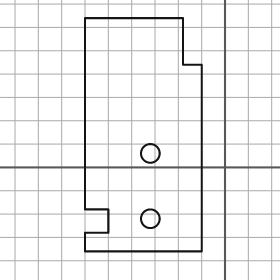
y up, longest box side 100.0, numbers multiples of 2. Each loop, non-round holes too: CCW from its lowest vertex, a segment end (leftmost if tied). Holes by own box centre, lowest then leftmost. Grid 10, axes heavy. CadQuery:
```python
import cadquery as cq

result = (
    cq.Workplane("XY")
    .moveTo(-60.0, -36.0)
    .lineTo(-10.0, -36.0)
    .lineTo(-10.0, 44.0)
    .lineTo(-18.0, 44.0)
    .lineTo(-18.0, 64.0)
    .lineTo(-60.0, 64.0)
    .lineTo(-60.0, -18.0)
    .lineTo(-50.0, -18.0)
    .lineTo(-50.0, -28.0)
    .lineTo(-60.0, -28.0)
    .close()
    .moveTo(-32.0, -22.0)
    .circle(4.0)
    .moveTo(-32.0, 6.0)
    .circle(4.0)
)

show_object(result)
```